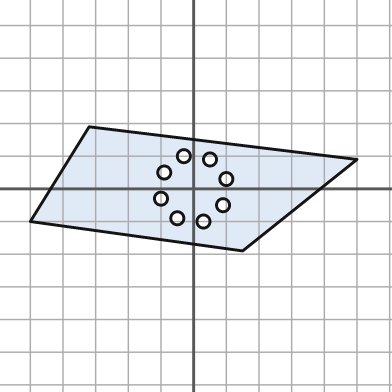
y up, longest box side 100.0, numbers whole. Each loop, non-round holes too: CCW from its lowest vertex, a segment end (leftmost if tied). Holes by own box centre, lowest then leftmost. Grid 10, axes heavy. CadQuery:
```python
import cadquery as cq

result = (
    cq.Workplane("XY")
    .moveTo(15.0, -19.0)
    .lineTo(50.0, 9.0)
    .lineTo(-32.0, 19.0)
    .lineTo(-50.0, -10.0)
    .close()
    .moveTo(3.0, -10.0)
    .circle(2.0)
    .moveTo(-5.0, -9.0)
    .circle(2.0)
    .moveTo(9.0, -5.0)
    .circle(2.0)
    .moveTo(-10.0, -3.0)
    .circle(2.0)
    .moveTo(10.0, 3.0)
    .circle(2.0)
    .moveTo(-9.0, 5.0)
    .circle(2.0)
    .moveTo(5.0, 9.0)
    .circle(2.0)
    .moveTo(-3.0, 10.0)
    .circle(2.0)
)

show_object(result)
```